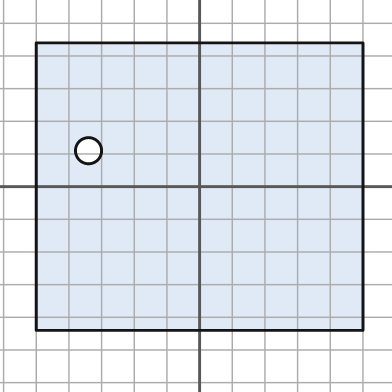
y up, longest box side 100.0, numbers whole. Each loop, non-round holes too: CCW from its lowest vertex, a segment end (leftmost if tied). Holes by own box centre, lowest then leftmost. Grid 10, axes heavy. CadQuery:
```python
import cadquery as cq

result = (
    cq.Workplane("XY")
    .moveTo(-50.0, -44.0)
    .lineTo(50.0, -44.0)
    .lineTo(50.0, 44.0)
    .lineTo(-50.0, 44.0)
    .close()
    .moveTo(-34.0, 11.0)
    .circle(4.0)
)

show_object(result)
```